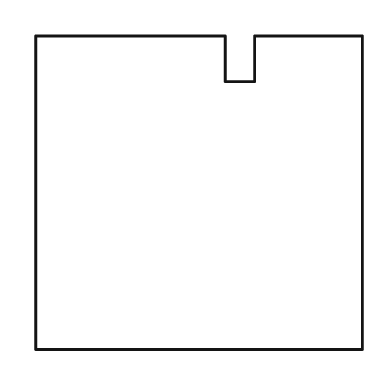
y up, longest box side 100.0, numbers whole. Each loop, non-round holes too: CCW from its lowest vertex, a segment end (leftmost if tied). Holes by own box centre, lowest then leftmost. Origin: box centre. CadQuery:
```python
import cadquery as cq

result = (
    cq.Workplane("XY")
    .moveTo(-50.0, -48.0)
    .lineTo(50.0, -48.0)
    .lineTo(50.0, 48.0)
    .lineTo(17.0, 48.0)
    .lineTo(17.0, 34.0)
    .lineTo(8.0, 34.0)
    .lineTo(8.0, 48.0)
    .lineTo(-50.0, 48.0)
    .close()
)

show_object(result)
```